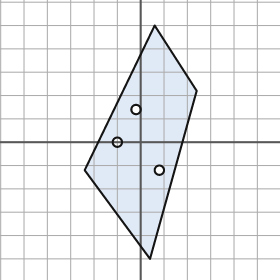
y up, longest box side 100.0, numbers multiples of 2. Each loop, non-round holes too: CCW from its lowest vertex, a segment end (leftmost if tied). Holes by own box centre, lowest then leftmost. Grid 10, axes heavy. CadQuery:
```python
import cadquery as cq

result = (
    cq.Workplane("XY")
    .moveTo(4.0, -50.0)
    .lineTo(24.0, 22.0)
    .lineTo(6.0, 50.0)
    .lineTo(-24.0, -12.0)
    .close()
    .moveTo(8.0, -12.0)
    .circle(2.0)
    .moveTo(-10.0, 0.0)
    .circle(2.0)
    .moveTo(-2.0, 14.0)
    .circle(2.0)
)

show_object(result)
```